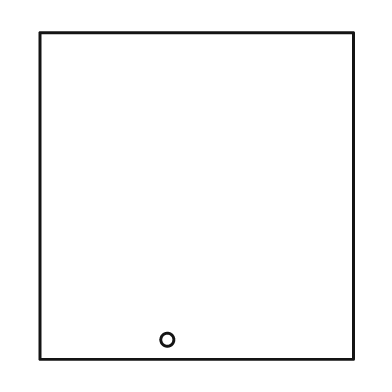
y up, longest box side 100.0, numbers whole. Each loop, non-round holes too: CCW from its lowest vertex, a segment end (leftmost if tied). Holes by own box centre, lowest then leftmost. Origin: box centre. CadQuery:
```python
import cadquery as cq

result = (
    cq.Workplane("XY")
    .moveTo(-48.0, -50.0)
    .lineTo(48.0, -50.0)
    .lineTo(48.0, 50.0)
    .lineTo(-48.0, 50.0)
    .close()
    .moveTo(-9.0, -44.0)
    .circle(2.0)
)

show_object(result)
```